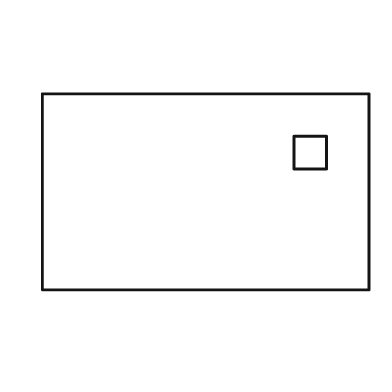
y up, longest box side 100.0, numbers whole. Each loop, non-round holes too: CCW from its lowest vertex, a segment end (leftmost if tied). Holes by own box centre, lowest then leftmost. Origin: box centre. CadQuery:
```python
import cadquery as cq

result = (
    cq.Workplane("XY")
    .moveTo(-50.0, -30.0)
    .lineTo(50.0, -30.0)
    .lineTo(50.0, 30.0)
    .lineTo(-50.0, 30.0)
    .close()
    .moveTo(27.0, 7.0)
    .lineTo(37.0, 7.0)
    .lineTo(37.0, 17.0)
    .lineTo(27.0, 17.0)
    .close()
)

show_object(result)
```